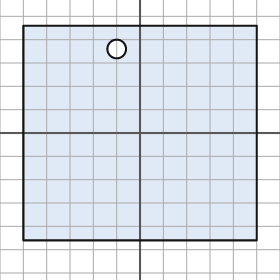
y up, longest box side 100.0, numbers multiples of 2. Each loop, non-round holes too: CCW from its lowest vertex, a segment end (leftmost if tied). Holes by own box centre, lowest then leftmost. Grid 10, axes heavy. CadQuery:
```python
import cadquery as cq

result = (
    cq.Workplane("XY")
    .moveTo(-50.0, -46.0)
    .lineTo(50.0, -46.0)
    .lineTo(50.0, 46.0)
    .lineTo(-50.0, 46.0)
    .close()
    .moveTo(-10.0, 36.0)
    .circle(4.0)
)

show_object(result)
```